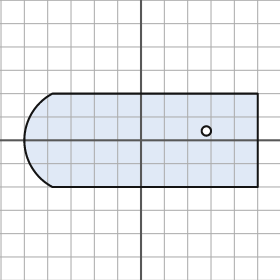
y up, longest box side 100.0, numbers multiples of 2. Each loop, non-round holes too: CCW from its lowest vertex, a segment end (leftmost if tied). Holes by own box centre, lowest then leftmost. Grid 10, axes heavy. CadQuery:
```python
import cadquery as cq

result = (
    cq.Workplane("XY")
    .moveTo(-38.0, -20.0)
    .lineTo(50.0, -20.0)
    .lineTo(50.0, 20.0)
    .lineTo(-38.0, 20.0)
    .threePointArc((-50.0, 0.0), (-38.0, -20.0))
    .close()
    .moveTo(28.0, 4.0)
    .circle(2.0)
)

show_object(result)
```